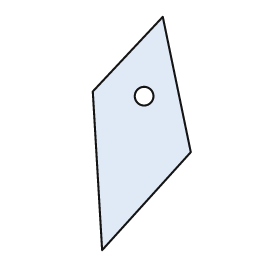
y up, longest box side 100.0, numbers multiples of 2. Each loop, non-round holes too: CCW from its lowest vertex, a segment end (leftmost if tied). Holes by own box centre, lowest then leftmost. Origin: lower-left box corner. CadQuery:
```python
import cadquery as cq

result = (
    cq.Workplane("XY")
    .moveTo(4.0, 0.0)
    .lineTo(42.0, 42.0)
    .lineTo(30.0, 100.0)
    .lineTo(0.0, 68.0)
    .close()
    .moveTo(22.0, 66.0)
    .circle(4.0)
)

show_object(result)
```